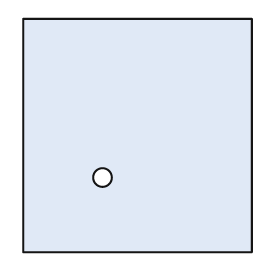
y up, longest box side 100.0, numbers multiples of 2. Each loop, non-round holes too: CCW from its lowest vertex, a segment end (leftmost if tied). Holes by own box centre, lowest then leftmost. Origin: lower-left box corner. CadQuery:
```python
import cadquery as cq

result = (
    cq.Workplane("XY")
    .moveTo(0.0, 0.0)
    .lineTo(98.0, 0.0)
    .lineTo(98.0, 100.0)
    .lineTo(0.0, 100.0)
    .close()
    .moveTo(34.0, 32.0)
    .circle(4.0)
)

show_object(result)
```